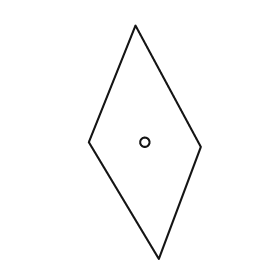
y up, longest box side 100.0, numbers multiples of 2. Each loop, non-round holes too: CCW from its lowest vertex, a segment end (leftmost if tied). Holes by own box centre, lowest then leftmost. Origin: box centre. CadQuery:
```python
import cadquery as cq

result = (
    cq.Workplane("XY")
    .moveTo(6.0, -50.0)
    .lineTo(24.0, -2.0)
    .lineTo(-4.0, 50.0)
    .lineTo(-24.0, 0.0)
    .close()
    .moveTo(0.0, 0.0)
    .circle(2.0)
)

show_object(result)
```